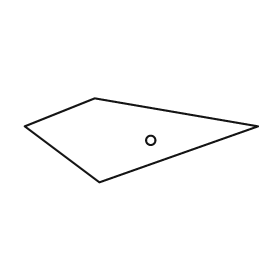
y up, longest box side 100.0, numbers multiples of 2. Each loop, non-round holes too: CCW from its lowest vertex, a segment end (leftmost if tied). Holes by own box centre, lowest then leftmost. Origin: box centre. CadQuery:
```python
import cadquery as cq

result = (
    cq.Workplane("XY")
    .moveTo(-18.0, -18.0)
    .lineTo(50.0, 6.0)
    .lineTo(-20.0, 18.0)
    .lineTo(-50.0, 6.0)
    .close()
    .moveTo(4.0, 0.0)
    .circle(2.0)
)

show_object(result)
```